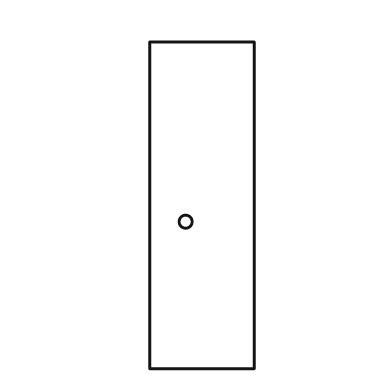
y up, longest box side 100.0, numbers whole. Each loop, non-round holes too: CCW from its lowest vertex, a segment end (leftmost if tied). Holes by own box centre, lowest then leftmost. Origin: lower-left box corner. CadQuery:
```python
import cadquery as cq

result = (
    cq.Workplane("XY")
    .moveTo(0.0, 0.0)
    .lineTo(32.0, 0.0)
    .lineTo(32.0, 100.0)
    .lineTo(0.0, 100.0)
    .close()
    .moveTo(11.0, 45.0)
    .circle(2.0)
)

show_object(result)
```